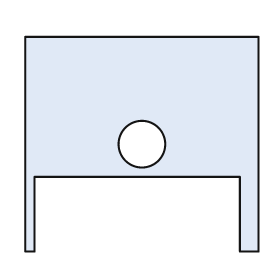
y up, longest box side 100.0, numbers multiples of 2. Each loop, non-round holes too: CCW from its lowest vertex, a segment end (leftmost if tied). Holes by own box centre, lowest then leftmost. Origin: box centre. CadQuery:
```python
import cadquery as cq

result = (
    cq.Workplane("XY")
    .moveTo(-50.0, -46.0)
    .lineTo(-46.0, -46.0)
    .lineTo(-46.0, -14.0)
    .lineTo(42.0, -14.0)
    .lineTo(42.0, -46.0)
    .lineTo(50.0, -46.0)
    .lineTo(50.0, 46.0)
    .lineTo(-50.0, 46.0)
    .close()
    .moveTo(0.0, 0.0)
    .circle(10.0)
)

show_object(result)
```